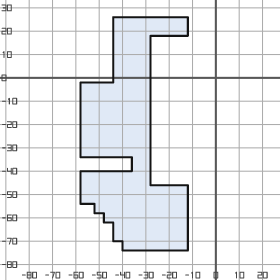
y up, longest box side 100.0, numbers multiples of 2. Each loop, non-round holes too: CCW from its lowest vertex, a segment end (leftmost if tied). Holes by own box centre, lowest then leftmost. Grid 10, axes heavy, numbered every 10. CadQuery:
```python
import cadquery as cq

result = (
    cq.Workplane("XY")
    .moveTo(-40.0, -74.0)
    .lineTo(-12.0, -74.0)
    .lineTo(-12.0, -46.0)
    .lineTo(-28.0, -46.0)
    .lineTo(-28.0, 18.0)
    .lineTo(-12.0, 18.0)
    .lineTo(-12.0, 26.0)
    .lineTo(-44.0, 26.0)
    .lineTo(-44.0, -2.0)
    .lineTo(-58.0, -2.0)
    .lineTo(-58.0, -34.0)
    .lineTo(-36.0, -34.0)
    .lineTo(-36.0, -40.0)
    .lineTo(-58.0, -40.0)
    .lineTo(-58.0, -54.0)
    .lineTo(-52.0, -54.0)
    .lineTo(-52.0, -58.0)
    .lineTo(-48.0, -58.0)
    .lineTo(-48.0, -62.0)
    .lineTo(-44.0, -62.0)
    .lineTo(-44.0, -70.0)
    .lineTo(-40.0, -70.0)
    .close()
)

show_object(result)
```